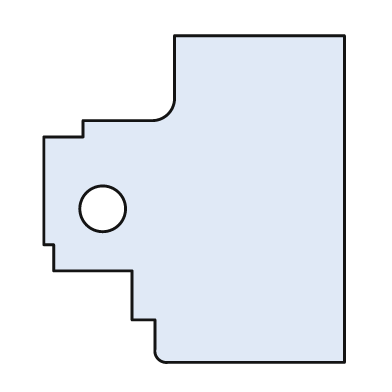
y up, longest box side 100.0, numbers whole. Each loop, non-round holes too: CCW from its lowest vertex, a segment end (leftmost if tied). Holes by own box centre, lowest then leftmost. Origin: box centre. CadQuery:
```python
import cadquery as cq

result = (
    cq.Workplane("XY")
    .moveTo(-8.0, -50.0)
    .lineTo(46.0, -50.0)
    .lineTo(46.0, 50.0)
    .lineTo(-6.0, 50.0)
    .lineTo(-6.0, 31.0)
    .threePointArc((-8.0, 26.0), (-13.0, 24.0))
    .lineTo(-34.0, 24.0)
    .lineTo(-34.0, 19.0)
    .lineTo(-46.0, 19.0)
    .lineTo(-46.0, -14.0)
    .lineTo(-43.0, -14.0)
    .lineTo(-43.0, -22.0)
    .lineTo(-19.0, -22.0)
    .lineTo(-19.0, -37.0)
    .lineTo(-12.0, -37.0)
    .lineTo(-12.0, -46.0)
    .threePointArc((-11.0, -49.0), (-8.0, -50.0))
    .close()
    .moveTo(-28.0, -3.0)
    .circle(7.0)
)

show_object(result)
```